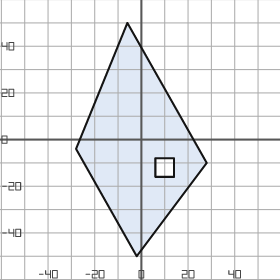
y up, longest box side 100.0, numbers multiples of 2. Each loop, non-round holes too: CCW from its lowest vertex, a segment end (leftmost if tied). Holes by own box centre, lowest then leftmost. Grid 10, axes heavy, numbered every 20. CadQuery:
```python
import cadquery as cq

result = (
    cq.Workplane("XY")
    .moveTo(-2.0, -50.0)
    .lineTo(28.0, -10.0)
    .lineTo(-6.0, 50.0)
    .lineTo(-28.0, -4.0)
    .close()
    .moveTo(6.0, -16.0)
    .lineTo(14.0, -16.0)
    .lineTo(14.0, -8.0)
    .lineTo(6.0, -8.0)
    .close()
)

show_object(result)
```